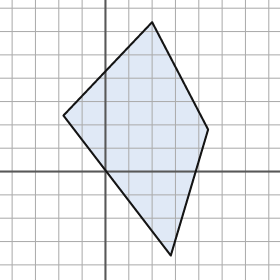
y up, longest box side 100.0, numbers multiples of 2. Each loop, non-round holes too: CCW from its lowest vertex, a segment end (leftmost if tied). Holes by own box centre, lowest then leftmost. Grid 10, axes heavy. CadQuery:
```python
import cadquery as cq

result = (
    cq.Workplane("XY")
    .moveTo(28.0, -36.0)
    .lineTo(44.0, 18.0)
    .lineTo(20.0, 64.0)
    .lineTo(-18.0, 24.0)
    .close()
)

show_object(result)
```